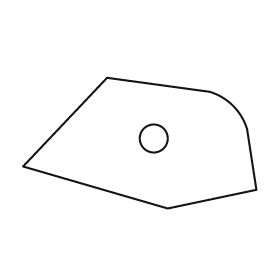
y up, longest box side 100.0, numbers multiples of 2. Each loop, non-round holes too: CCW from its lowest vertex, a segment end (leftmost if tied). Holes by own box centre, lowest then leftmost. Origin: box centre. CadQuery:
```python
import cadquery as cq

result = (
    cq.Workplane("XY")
    .moveTo(12.0, -28.0)
    .lineTo(50.0, -20.0)
    .lineTo(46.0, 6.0)
    .threePointArc((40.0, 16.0), (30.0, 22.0))
    .lineTo(-14.0, 28.0)
    .lineTo(-50.0, -10.0)
    .close()
    .moveTo(6.0, 2.0)
    .circle(6.0)
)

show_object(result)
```